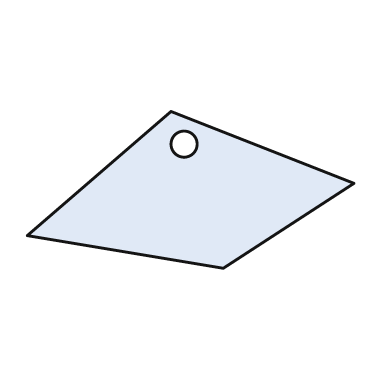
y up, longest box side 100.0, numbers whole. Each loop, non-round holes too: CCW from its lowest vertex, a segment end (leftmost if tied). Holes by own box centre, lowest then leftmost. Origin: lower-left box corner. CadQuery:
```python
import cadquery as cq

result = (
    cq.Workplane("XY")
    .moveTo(60.0, 0.0)
    .lineTo(100.0, 26.0)
    .lineTo(44.0, 48.0)
    .lineTo(0.0, 10.0)
    .close()
    .moveTo(48.0, 38.0)
    .circle(4.0)
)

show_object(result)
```